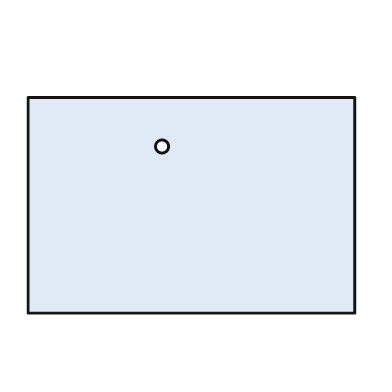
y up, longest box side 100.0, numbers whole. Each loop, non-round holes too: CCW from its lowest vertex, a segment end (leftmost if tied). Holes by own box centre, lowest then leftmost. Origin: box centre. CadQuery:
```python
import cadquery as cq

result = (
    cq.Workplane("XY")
    .moveTo(-50.0, -33.0)
    .lineTo(50.0, -33.0)
    .lineTo(50.0, 33.0)
    .lineTo(-50.0, 33.0)
    .close()
    .moveTo(-9.0, 18.0)
    .circle(2.0)
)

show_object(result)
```